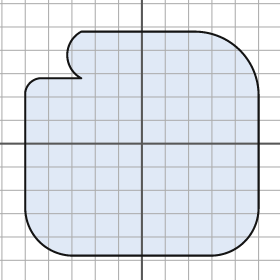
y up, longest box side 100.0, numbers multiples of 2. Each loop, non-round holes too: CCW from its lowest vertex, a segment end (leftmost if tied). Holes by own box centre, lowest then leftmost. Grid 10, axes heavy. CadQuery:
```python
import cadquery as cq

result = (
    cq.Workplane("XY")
    .moveTo(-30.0, -48.0)
    .lineTo(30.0, -48.0)
    .threePointArc((44.0, -42.0), (50.0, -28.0))
    .lineTo(50.0, 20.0)
    .threePointArc((42.0, 40.0), (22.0, 48.0))
    .lineTo(-26.0, 48.0)
    .threePointArc((-32.0, 38.0), (-26.0, 28.0))
    .lineTo(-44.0, 28.0)
    .threePointArc((-48.0, 26.0), (-50.0, 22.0))
    .lineTo(-50.0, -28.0)
    .threePointArc((-44.0, -42.0), (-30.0, -48.0))
    .close()
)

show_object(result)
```